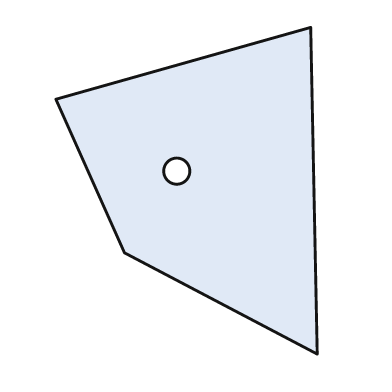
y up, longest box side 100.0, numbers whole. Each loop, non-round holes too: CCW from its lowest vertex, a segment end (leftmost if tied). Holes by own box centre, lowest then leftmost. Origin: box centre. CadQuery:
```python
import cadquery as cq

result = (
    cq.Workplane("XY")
    .moveTo(40.0, -50.0)
    .lineTo(38.0, 50.0)
    .lineTo(-40.0, 28.0)
    .lineTo(-19.0, -19.0)
    .close()
    .moveTo(-3.0, 6.0)
    .circle(4.0)
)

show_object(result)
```